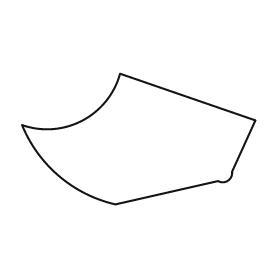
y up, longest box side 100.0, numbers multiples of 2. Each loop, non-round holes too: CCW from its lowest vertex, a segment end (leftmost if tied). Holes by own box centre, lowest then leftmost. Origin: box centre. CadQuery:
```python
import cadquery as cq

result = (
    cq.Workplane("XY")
    .moveTo(-10.0, -28.0)
    .lineTo(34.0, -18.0)
    .threePointArc((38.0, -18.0), (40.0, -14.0))
    .lineTo(50.0, 8.0)
    .lineTo(-8.0, 28.0)
    .threePointArc((-24.0, 8.0), (-50.0, 6.0))
    .threePointArc((-34.0, -16.0), (-10.0, -28.0))
    .close()
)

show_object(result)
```